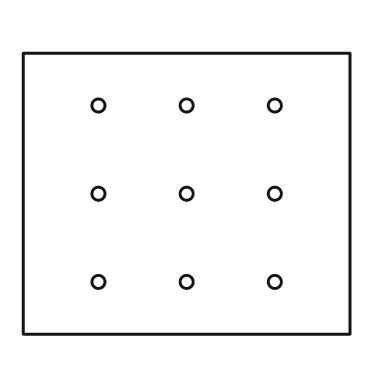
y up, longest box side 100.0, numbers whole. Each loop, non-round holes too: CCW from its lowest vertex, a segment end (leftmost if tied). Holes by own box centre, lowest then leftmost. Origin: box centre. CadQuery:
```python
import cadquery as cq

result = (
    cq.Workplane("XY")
    .moveTo(-50.0, -43.0)
    .lineTo(50.0, -43.0)
    .lineTo(50.0, 43.0)
    .lineTo(-50.0, 43.0)
    .close()
    .moveTo(-27.0, -27.0)
    .circle(2.0)
    .moveTo(0.0, -27.0)
    .circle(2.0)
    .moveTo(27.0, -27.0)
    .circle(2.0)
    .moveTo(-27.0, 0.0)
    .circle(2.0)
    .moveTo(0.0, 0.0)
    .circle(2.0)
    .moveTo(27.0, 0.0)
    .circle(2.0)
    .moveTo(-27.0, 27.0)
    .circle(2.0)
    .moveTo(0.0, 27.0)
    .circle(2.0)
    .moveTo(27.0, 27.0)
    .circle(2.0)
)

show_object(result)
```